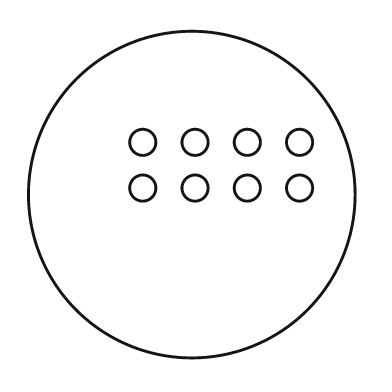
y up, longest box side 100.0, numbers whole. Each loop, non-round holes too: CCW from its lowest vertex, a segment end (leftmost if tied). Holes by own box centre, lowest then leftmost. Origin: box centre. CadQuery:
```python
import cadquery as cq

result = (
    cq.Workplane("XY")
    .moveTo(0.0, 0.0)
    .circle(50.0)
    .moveTo(-15.0, 2.0)
    .circle(4.0)
    .moveTo(1.0, 2.0)
    .circle(4.0)
    .moveTo(17.0, 2.0)
    .circle(4.0)
    .moveTo(33.0, 2.0)
    .circle(4.0)
    .moveTo(-15.0, 16.0)
    .circle(4.0)
    .moveTo(1.0, 16.0)
    .circle(4.0)
    .moveTo(17.0, 16.0)
    .circle(4.0)
    .moveTo(33.0, 16.0)
    .circle(4.0)
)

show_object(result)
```